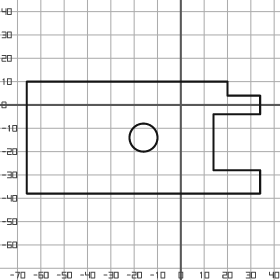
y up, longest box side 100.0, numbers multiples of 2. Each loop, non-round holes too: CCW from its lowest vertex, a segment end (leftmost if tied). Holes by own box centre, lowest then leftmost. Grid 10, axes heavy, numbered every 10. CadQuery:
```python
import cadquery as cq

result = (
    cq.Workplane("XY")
    .moveTo(-66.0, -38.0)
    .lineTo(34.0, -38.0)
    .lineTo(34.0, -28.0)
    .lineTo(14.0, -28.0)
    .lineTo(14.0, -4.0)
    .lineTo(34.0, -4.0)
    .lineTo(34.0, 4.0)
    .lineTo(20.0, 4.0)
    .lineTo(20.0, 10.0)
    .lineTo(-66.0, 10.0)
    .close()
    .moveTo(-16.0, -14.0)
    .circle(6.0)
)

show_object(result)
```